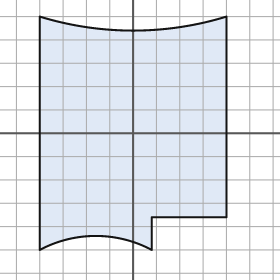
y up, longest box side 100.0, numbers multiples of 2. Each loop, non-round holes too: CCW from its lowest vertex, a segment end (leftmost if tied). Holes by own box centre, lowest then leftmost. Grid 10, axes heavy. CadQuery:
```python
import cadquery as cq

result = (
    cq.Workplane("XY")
    .moveTo(-40.0, -50.0)
    .threePointArc((-16.0, -44.0), (8.0, -50.0))
    .lineTo(8.0, -36.0)
    .lineTo(40.0, -36.0)
    .lineTo(40.0, 50.0)
    .threePointArc((0.0, 44.0), (-40.0, 50.0))
    .close()
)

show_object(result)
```